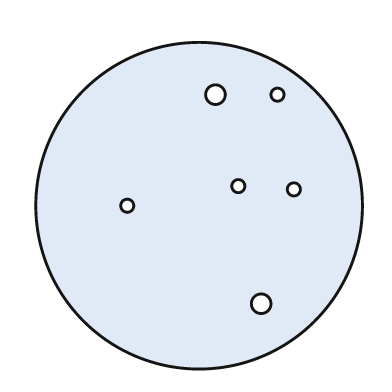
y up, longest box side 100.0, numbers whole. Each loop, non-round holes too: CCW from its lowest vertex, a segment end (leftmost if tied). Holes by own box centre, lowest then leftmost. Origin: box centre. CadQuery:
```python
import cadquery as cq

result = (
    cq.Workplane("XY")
    .moveTo(0.0, 0.0)
    .circle(50.0)
    .moveTo(19.0, -30.0)
    .circle(3.0)
    .moveTo(-22.0, 0.0)
    .circle(2.0)
    .moveTo(29.0, 5.0)
    .circle(2.0)
    .moveTo(12.0, 6.0)
    .circle(2.0)
    .moveTo(5.0, 34.0)
    .circle(3.0)
    .moveTo(24.0, 34.0)
    .circle(2.0)
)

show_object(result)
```